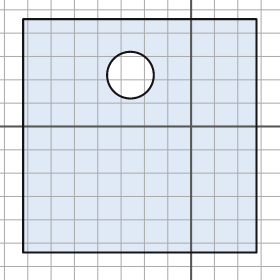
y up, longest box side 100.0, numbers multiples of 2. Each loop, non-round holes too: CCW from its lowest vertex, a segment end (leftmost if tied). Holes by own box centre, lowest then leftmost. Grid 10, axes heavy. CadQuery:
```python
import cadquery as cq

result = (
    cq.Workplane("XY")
    .moveTo(-72.0, -54.0)
    .lineTo(28.0, -54.0)
    .lineTo(28.0, 46.0)
    .lineTo(-72.0, 46.0)
    .close()
    .moveTo(-26.0, 22.0)
    .circle(10.0)
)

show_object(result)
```